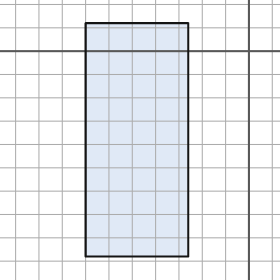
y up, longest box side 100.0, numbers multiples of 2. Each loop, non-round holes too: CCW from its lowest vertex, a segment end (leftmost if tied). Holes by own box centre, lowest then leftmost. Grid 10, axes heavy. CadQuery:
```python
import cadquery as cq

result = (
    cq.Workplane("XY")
    .moveTo(-70.0, -88.0)
    .lineTo(-26.0, -88.0)
    .lineTo(-26.0, 12.0)
    .lineTo(-70.0, 12.0)
    .close()
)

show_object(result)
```